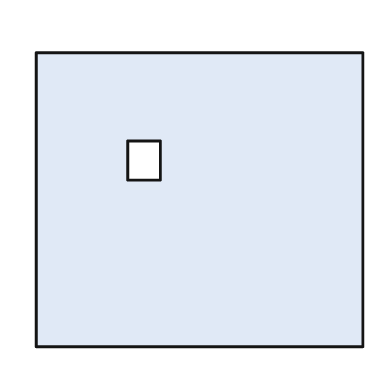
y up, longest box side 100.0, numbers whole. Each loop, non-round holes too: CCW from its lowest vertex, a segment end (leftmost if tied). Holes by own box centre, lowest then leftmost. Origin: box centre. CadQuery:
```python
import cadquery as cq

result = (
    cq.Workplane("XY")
    .moveTo(-50.0, -45.0)
    .lineTo(50.0, -45.0)
    .lineTo(50.0, 45.0)
    .lineTo(-50.0, 45.0)
    .close()
    .moveTo(-22.0, 6.0)
    .lineTo(-12.0, 6.0)
    .lineTo(-12.0, 18.0)
    .lineTo(-22.0, 18.0)
    .close()
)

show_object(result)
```